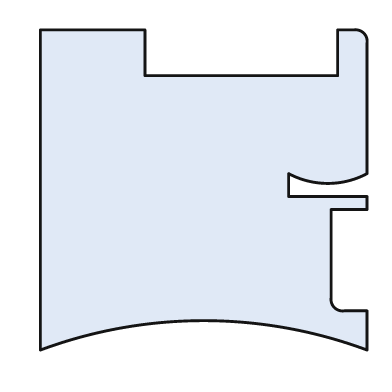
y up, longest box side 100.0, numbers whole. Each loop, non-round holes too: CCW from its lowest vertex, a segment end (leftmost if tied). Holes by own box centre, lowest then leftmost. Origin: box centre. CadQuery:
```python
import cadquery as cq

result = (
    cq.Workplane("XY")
    .moveTo(-50.0, -49.0)
    .threePointArc((0.0, -40.0), (50.0, -49.0))
    .lineTo(50.0, -37.0)
    .lineTo(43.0, -37.0)
    .threePointArc((40.0, -36.0), (39.0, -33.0))
    .lineTo(39.0, -6.0)
    .lineTo(50.0, -6.0)
    .lineTo(50.0, -2.0)
    .lineTo(26.0, -2.0)
    .lineTo(26.0, 5.0)
    .threePointArc((38.0, 2.0), (50.0, 5.0))
    .lineTo(50.0, 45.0)
    .threePointArc((49.0, 48.0), (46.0, 49.0))
    .lineTo(41.0, 49.0)
    .lineTo(41.0, 35.0)
    .lineTo(-18.0, 35.0)
    .lineTo(-18.0, 49.0)
    .lineTo(-50.0, 49.0)
    .close()
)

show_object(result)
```